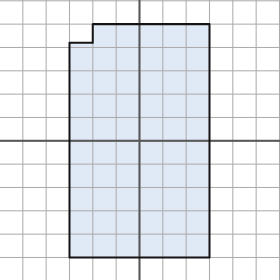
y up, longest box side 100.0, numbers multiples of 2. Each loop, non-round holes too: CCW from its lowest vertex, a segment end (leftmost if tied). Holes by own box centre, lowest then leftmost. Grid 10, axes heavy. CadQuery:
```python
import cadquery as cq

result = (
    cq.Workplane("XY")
    .moveTo(-30.0, -50.0)
    .lineTo(30.0, -50.0)
    .lineTo(30.0, 50.0)
    .lineTo(-20.0, 50.0)
    .lineTo(-20.0, 42.0)
    .lineTo(-30.0, 42.0)
    .close()
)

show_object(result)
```